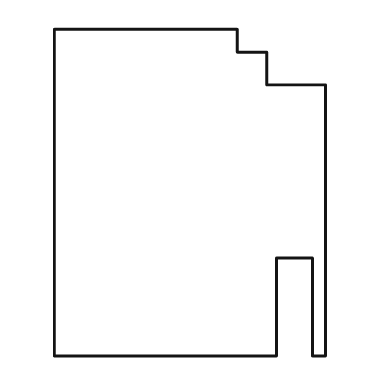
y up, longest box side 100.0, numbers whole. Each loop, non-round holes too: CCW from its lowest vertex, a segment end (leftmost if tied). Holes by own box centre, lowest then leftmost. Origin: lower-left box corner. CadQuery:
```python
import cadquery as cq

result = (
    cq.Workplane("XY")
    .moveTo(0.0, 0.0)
    .lineTo(68.0, 0.0)
    .lineTo(68.0, 30.0)
    .lineTo(79.0, 30.0)
    .lineTo(79.0, 0.0)
    .lineTo(83.0, 0.0)
    .lineTo(83.0, 83.0)
    .lineTo(65.0, 83.0)
    .lineTo(65.0, 93.0)
    .lineTo(56.0, 93.0)
    .lineTo(56.0, 100.0)
    .lineTo(0.0, 100.0)
    .close()
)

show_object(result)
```